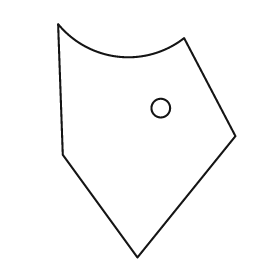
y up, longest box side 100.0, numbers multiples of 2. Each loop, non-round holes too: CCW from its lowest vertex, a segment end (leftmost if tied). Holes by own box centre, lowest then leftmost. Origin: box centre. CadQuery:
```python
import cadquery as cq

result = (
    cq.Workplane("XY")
    .moveTo(-4.0, -50.0)
    .lineTo(38.0, 2.0)
    .lineTo(16.0, 44.0)
    .threePointArc((-12.0, 36.0), (-38.0, 50.0))
    .lineTo(-36.0, -6.0)
    .close()
    .moveTo(6.0, 14.0)
    .circle(4.0)
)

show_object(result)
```